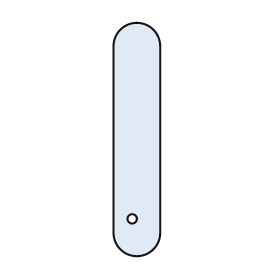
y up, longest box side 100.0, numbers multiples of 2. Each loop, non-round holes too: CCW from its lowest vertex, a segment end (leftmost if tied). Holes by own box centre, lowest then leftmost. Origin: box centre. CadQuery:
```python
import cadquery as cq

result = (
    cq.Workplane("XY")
    .moveTo(-10.0, -40.0)
    .threePointArc((0.0, -50.0), (10.0, -40.0))
    .lineTo(10.0, 40.0)
    .threePointArc((0.0, 50.0), (-10.0, 40.0))
    .close()
    .moveTo(-2.0, -34.0)
    .circle(2.0)
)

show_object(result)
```